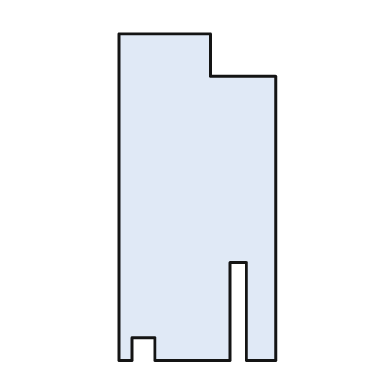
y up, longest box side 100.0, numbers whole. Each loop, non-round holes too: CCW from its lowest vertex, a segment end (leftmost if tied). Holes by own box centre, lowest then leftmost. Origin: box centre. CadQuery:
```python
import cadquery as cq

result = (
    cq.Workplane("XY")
    .moveTo(-24.0, -50.0)
    .lineTo(-20.0, -50.0)
    .lineTo(-20.0, -43.0)
    .lineTo(-13.0, -43.0)
    .lineTo(-13.0, -50.0)
    .lineTo(10.0, -50.0)
    .lineTo(10.0, -20.0)
    .lineTo(15.0, -20.0)
    .lineTo(15.0, -50.0)
    .lineTo(24.0, -50.0)
    .lineTo(24.0, 37.0)
    .lineTo(4.0, 37.0)
    .lineTo(4.0, 50.0)
    .lineTo(-24.0, 50.0)
    .close()
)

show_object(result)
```